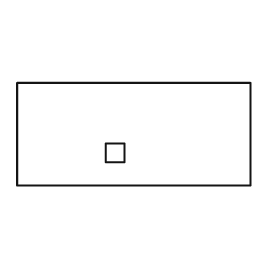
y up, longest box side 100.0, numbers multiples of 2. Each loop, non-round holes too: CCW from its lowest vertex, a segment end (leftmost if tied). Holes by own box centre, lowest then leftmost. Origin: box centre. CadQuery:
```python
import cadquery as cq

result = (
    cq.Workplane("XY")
    .moveTo(-50.0, -22.0)
    .lineTo(50.0, -22.0)
    .lineTo(50.0, 22.0)
    .lineTo(-50.0, 22.0)
    .close()
    .moveTo(-12.0, -12.0)
    .lineTo(-4.0, -12.0)
    .lineTo(-4.0, -4.0)
    .lineTo(-12.0, -4.0)
    .close()
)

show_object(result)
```